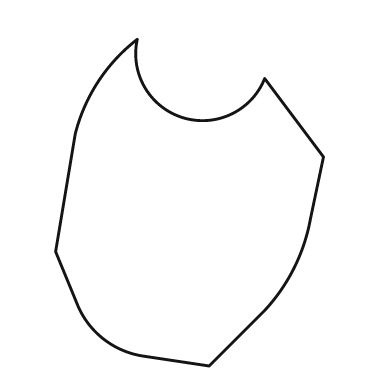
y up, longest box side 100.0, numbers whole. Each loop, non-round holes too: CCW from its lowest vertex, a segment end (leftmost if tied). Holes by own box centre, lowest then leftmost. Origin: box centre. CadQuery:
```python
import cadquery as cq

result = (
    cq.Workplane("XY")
    .moveTo(6.0, -50.0)
    .lineTo(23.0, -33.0)
    .threePointArc((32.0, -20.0), (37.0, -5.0))
    .lineTo(41.0, 14.0)
    .lineTo(23.0, 38.0)
    .threePointArc((-2.0, 26.0), (-16.0, 50.0))
    .threePointArc((-28.0, 37.0), (-35.0, 21.0))
    .lineTo(-41.0, -15.0)
    .lineTo(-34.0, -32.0)
    .threePointArc((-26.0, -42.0), (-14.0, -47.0))
    .close()
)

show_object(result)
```